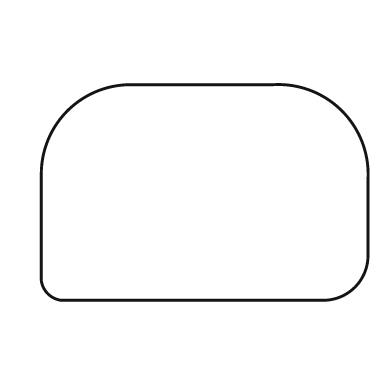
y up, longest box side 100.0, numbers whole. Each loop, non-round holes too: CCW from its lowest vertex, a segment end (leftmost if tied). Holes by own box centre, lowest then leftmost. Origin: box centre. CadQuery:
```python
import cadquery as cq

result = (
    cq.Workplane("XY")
    .moveTo(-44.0, -33.0)
    .lineTo(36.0, -33.0)
    .threePointArc((46.0, -29.0), (50.0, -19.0))
    .lineTo(50.0, 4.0)
    .threePointArc((42.0, 25.0), (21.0, 33.0))
    .lineTo(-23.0, 33.0)
    .threePointArc((-42.0, 25.0), (-50.0, 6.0))
    .lineTo(-50.0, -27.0)
    .threePointArc((-48.0, -31.0), (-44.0, -33.0))
    .close()
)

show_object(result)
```